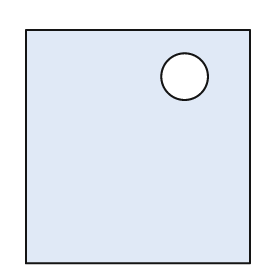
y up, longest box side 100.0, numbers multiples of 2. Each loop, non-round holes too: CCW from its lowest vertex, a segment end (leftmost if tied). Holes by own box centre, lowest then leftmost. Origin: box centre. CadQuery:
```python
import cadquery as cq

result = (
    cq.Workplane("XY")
    .moveTo(-48.0, -50.0)
    .lineTo(48.0, -50.0)
    .lineTo(48.0, 50.0)
    .lineTo(-48.0, 50.0)
    .close()
    .moveTo(20.0, 30.0)
    .circle(10.0)
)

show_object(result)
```